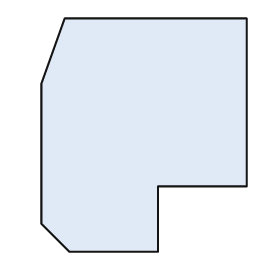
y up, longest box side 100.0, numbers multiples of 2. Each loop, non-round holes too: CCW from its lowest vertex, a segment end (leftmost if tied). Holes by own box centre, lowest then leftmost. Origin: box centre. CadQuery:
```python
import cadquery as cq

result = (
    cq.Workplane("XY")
    .moveTo(-32.0, -50.0)
    .lineTo(6.0, -50.0)
    .lineTo(6.0, -22.0)
    .lineTo(44.0, -22.0)
    .lineTo(44.0, 50.0)
    .lineTo(-34.0, 50.0)
    .lineTo(-44.0, 22.0)
    .lineTo(-44.0, -38.0)
    .close()
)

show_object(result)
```